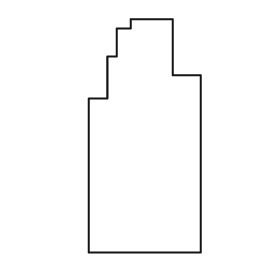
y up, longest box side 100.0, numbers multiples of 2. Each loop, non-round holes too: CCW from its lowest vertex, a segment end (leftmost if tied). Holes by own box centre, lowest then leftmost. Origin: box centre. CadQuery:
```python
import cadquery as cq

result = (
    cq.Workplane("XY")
    .moveTo(-24.0, -50.0)
    .lineTo(24.0, -50.0)
    .lineTo(24.0, 26.0)
    .lineTo(12.0, 26.0)
    .lineTo(12.0, 50.0)
    .lineTo(-6.0, 50.0)
    .lineTo(-6.0, 46.0)
    .lineTo(-12.0, 46.0)
    .lineTo(-12.0, 34.0)
    .lineTo(-16.0, 34.0)
    .lineTo(-16.0, 16.0)
    .lineTo(-24.0, 16.0)
    .close()
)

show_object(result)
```